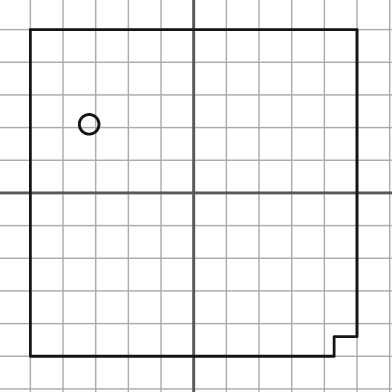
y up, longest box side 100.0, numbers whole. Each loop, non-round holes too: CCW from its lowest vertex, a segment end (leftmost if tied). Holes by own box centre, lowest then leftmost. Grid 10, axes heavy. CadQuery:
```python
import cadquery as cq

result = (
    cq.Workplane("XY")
    .moveTo(-50.0, -50.0)
    .lineTo(43.0, -50.0)
    .lineTo(43.0, -44.0)
    .lineTo(50.0, -44.0)
    .lineTo(50.0, 50.0)
    .lineTo(-50.0, 50.0)
    .close()
    .moveTo(-32.0, 21.0)
    .circle(3.0)
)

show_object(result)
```